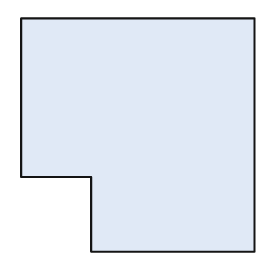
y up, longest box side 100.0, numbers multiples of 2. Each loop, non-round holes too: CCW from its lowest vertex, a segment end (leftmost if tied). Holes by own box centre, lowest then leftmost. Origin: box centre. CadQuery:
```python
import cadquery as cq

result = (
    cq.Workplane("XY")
    .moveTo(-20.0, -50.0)
    .lineTo(50.0, -50.0)
    .lineTo(50.0, 50.0)
    .lineTo(-50.0, 50.0)
    .lineTo(-50.0, -18.0)
    .lineTo(-20.0, -18.0)
    .close()
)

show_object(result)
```